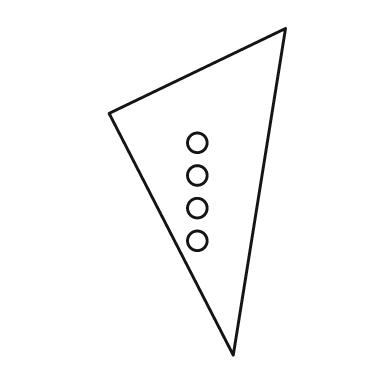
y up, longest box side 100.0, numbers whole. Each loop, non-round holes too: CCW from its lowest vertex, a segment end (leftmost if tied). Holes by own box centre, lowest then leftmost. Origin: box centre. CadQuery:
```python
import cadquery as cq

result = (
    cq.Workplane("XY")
    .moveTo(11.0, -50.0)
    .lineTo(27.0, 50.0)
    .lineTo(-27.0, 24.0)
    .close()
    .moveTo(0.0, -15.0)
    .circle(3.0)
    .moveTo(0.0, -5.0)
    .circle(3.0)
    .moveTo(0.0, 5.0)
    .circle(3.0)
    .moveTo(0.0, 15.0)
    .circle(3.0)
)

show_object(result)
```